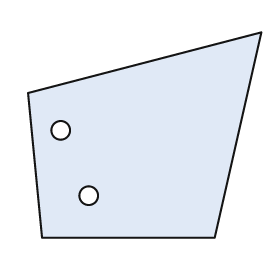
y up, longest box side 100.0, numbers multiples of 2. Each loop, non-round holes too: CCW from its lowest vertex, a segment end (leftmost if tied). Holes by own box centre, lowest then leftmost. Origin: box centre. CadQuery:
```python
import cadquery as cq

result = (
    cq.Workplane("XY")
    .moveTo(-44.0, -44.0)
    .lineTo(30.0, -44.0)
    .lineTo(50.0, 44.0)
    .lineTo(-50.0, 18.0)
    .close()
    .moveTo(-24.0, -26.0)
    .circle(4.0)
    .moveTo(-36.0, 2.0)
    .circle(4.0)
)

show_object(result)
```